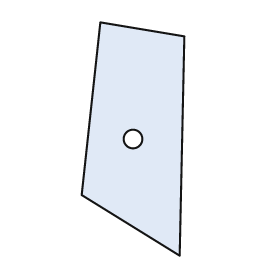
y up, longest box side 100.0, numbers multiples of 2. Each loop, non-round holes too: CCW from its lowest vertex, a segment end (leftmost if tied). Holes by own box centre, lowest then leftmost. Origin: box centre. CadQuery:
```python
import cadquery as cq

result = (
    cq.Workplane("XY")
    .moveTo(20.0, -50.0)
    .lineTo(22.0, 44.0)
    .lineTo(-14.0, 50.0)
    .lineTo(-22.0, -24.0)
    .close()
    .moveTo(0.0, 0.0)
    .circle(4.0)
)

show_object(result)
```